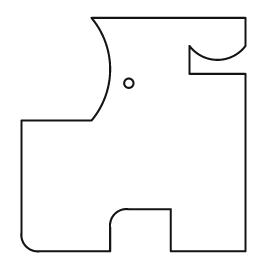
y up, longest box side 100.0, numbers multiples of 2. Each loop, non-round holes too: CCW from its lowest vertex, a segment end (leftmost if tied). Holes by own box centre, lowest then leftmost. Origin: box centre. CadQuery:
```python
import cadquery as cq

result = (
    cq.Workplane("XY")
    .moveTo(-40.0, -50.0)
    .lineTo(-10.0, -50.0)
    .lineTo(-10.0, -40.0)
    .threePointArc((-8.0, -34.0), (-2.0, -32.0))
    .lineTo(16.0, -32.0)
    .lineTo(16.0, -50.0)
    .lineTo(48.0, -50.0)
    .lineTo(48.0, 26.0)
    .lineTo(24.0, 26.0)
    .lineTo(24.0, 38.0)
    .threePointArc((36.0, 32.0), (48.0, 38.0))
    .lineTo(48.0, 50.0)
    .lineTo(-18.0, 50.0)
    .threePointArc((-10.0, 28.0), (-18.0, 6.0))
    .lineTo(-48.0, 6.0)
    .lineTo(-48.0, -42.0)
    .threePointArc((-46.0, -48.0), (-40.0, -50.0))
    .close()
    .moveTo(-2.0, 22.0)
    .circle(2.0)
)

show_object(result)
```